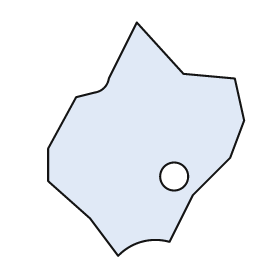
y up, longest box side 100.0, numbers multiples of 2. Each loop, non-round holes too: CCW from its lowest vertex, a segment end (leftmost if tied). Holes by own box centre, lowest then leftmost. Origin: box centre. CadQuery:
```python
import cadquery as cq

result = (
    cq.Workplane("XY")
    .moveTo(-12.0, -50.0)
    .threePointArc((-2.0, -44.0), (10.0, -44.0))
    .lineTo(20.0, -24.0)
    .lineTo(36.0, -8.0)
    .lineTo(42.0, 8.0)
    .lineTo(38.0, 26.0)
    .lineTo(16.0, 28.0)
    .lineTo(-4.0, 50.0)
    .lineTo(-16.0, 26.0)
    .threePointArc((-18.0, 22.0), (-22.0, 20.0))
    .lineTo(-30.0, 18.0)
    .lineTo(-42.0, -4.0)
    .lineTo(-42.0, -18.0)
    .lineTo(-24.0, -34.0)
    .close()
    .moveTo(12.0, -16.0)
    .circle(6.0)
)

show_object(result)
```